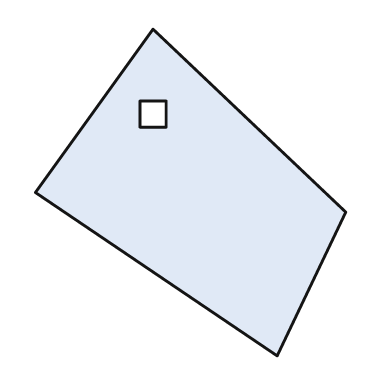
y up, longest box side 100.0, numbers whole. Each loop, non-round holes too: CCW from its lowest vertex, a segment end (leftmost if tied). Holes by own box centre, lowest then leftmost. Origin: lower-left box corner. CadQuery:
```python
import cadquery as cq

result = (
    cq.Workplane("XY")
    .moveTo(74.0, 0.0)
    .lineTo(95.0, 44.0)
    .lineTo(36.0, 100.0)
    .lineTo(0.0, 50.0)
    .close()
    .moveTo(32.0, 70.0)
    .lineTo(40.0, 70.0)
    .lineTo(40.0, 78.0)
    .lineTo(32.0, 78.0)
    .close()
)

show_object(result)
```